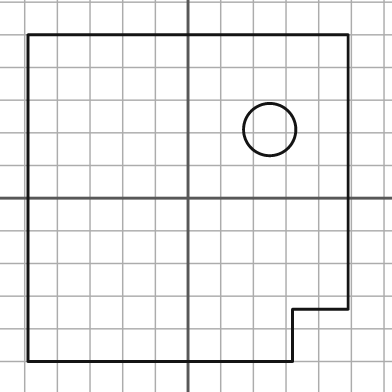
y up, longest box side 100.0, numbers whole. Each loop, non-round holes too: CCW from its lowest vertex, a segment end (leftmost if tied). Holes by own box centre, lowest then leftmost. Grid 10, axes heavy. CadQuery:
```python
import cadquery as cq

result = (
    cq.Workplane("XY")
    .moveTo(-49.0, -50.0)
    .lineTo(32.0, -50.0)
    .lineTo(32.0, -34.0)
    .lineTo(49.0, -34.0)
    .lineTo(49.0, 50.0)
    .lineTo(-49.0, 50.0)
    .close()
    .moveTo(25.0, 21.0)
    .circle(8.0)
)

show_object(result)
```